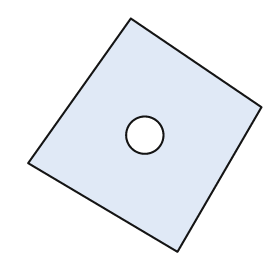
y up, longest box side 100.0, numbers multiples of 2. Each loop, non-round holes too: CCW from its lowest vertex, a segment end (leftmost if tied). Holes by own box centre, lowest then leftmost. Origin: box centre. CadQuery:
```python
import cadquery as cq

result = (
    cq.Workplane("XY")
    .moveTo(14.0, -50.0)
    .lineTo(50.0, 12.0)
    .lineTo(-6.0, 50.0)
    .lineTo(-50.0, -12.0)
    .close()
    .moveTo(0.0, 0.0)
    .circle(8.0)
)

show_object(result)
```